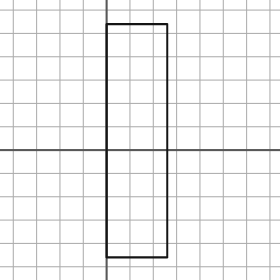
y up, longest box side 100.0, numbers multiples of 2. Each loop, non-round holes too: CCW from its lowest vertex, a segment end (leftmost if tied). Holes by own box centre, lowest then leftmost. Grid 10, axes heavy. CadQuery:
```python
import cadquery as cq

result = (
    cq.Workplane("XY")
    .moveTo(0.0, -46.0)
    .lineTo(26.0, -46.0)
    .lineTo(26.0, 54.0)
    .lineTo(0.0, 54.0)
    .close()
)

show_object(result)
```